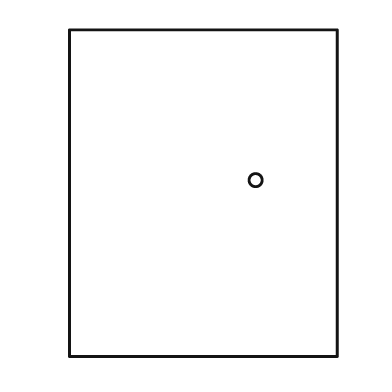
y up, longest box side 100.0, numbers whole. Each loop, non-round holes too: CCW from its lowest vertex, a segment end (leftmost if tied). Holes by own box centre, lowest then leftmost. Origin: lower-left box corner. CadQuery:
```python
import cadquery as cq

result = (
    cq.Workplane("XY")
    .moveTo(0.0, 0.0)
    .lineTo(82.0, 0.0)
    .lineTo(82.0, 100.0)
    .lineTo(0.0, 100.0)
    .close()
    .moveTo(57.0, 54.0)
    .circle(2.0)
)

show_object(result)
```